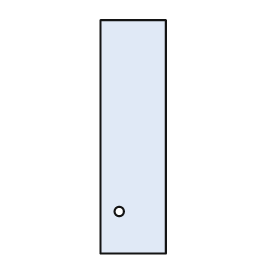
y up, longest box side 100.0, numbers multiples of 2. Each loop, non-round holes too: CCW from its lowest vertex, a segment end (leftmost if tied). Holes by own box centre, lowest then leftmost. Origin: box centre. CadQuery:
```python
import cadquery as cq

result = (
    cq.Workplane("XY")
    .moveTo(-14.0, -50.0)
    .lineTo(14.0, -50.0)
    .lineTo(14.0, 50.0)
    .lineTo(-14.0, 50.0)
    .close()
    .moveTo(-6.0, -32.0)
    .circle(2.0)
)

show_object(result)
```